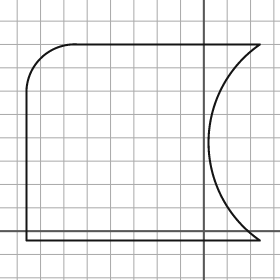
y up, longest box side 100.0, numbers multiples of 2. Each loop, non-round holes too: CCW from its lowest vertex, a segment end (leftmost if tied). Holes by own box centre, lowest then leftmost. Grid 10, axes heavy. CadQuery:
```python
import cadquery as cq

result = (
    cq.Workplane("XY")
    .moveTo(-76.0, -4.0)
    .lineTo(24.0, -4.0)
    .threePointArc((2.0, 38.0), (24.0, 80.0))
    .lineTo(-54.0, 80.0)
    .threePointArc((-70.0, 74.0), (-76.0, 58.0))
    .close()
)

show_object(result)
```